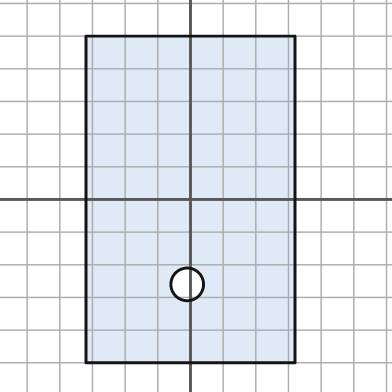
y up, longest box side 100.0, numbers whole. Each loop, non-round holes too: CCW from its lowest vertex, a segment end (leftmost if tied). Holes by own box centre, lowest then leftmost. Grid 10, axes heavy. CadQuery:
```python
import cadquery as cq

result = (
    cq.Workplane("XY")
    .moveTo(-32.0, -50.0)
    .lineTo(32.0, -50.0)
    .lineTo(32.0, 50.0)
    .lineTo(-32.0, 50.0)
    .close()
    .moveTo(-1.0, -26.0)
    .circle(5.0)
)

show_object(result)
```